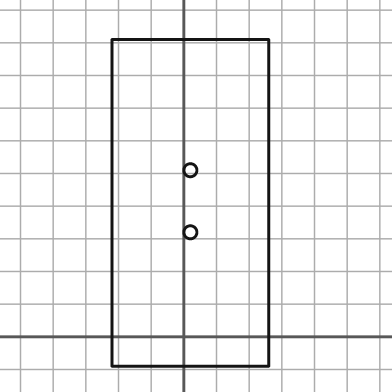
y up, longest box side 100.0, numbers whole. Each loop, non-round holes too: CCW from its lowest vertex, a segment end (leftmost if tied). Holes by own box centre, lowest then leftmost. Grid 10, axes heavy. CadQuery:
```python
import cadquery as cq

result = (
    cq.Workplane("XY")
    .moveTo(-22.0, -9.0)
    .lineTo(26.0, -9.0)
    .lineTo(26.0, 91.0)
    .lineTo(-22.0, 91.0)
    .close()
    .moveTo(2.0, 32.0)
    .circle(2.0)
    .moveTo(2.0, 51.0)
    .circle(2.0)
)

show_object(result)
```